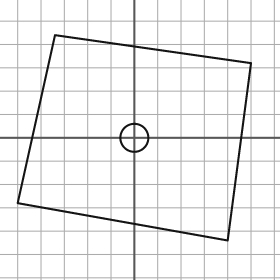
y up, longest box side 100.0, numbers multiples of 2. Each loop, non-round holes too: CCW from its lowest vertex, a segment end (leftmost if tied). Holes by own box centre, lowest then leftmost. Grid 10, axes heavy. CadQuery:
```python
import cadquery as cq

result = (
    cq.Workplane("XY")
    .moveTo(40.0, -44.0)
    .lineTo(50.0, 32.0)
    .lineTo(-34.0, 44.0)
    .lineTo(-50.0, -28.0)
    .close()
    .moveTo(0.0, 0.0)
    .circle(6.0)
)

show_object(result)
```